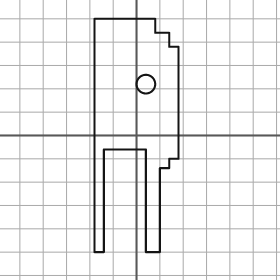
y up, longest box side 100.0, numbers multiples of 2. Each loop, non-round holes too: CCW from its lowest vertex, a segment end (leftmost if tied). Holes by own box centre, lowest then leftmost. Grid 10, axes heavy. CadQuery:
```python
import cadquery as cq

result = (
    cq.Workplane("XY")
    .moveTo(-18.0, -50.0)
    .lineTo(-14.0, -50.0)
    .lineTo(-14.0, -6.0)
    .lineTo(4.0, -6.0)
    .lineTo(4.0, -50.0)
    .lineTo(10.0, -50.0)
    .lineTo(10.0, -14.0)
    .lineTo(14.0, -14.0)
    .lineTo(14.0, -10.0)
    .lineTo(18.0, -10.0)
    .lineTo(18.0, 38.0)
    .lineTo(14.0, 38.0)
    .lineTo(14.0, 44.0)
    .lineTo(8.0, 44.0)
    .lineTo(8.0, 50.0)
    .lineTo(-18.0, 50.0)
    .close()
    .moveTo(4.0, 22.0)
    .circle(4.0)
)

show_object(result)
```